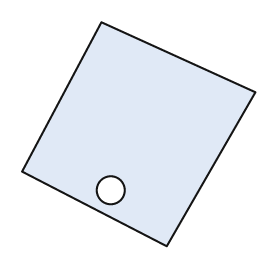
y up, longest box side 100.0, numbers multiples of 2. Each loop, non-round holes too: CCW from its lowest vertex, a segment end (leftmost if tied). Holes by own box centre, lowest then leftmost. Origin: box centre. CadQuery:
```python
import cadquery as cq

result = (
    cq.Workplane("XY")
    .moveTo(12.0, -48.0)
    .lineTo(50.0, 18.0)
    .lineTo(-16.0, 48.0)
    .lineTo(-50.0, -16.0)
    .close()
    .moveTo(-12.0, -24.0)
    .circle(6.0)
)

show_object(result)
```